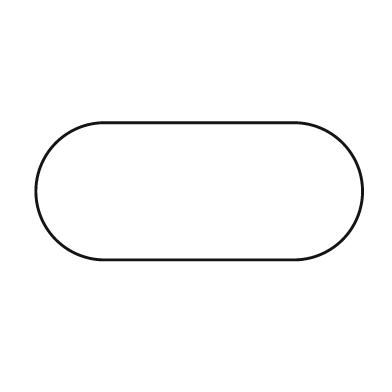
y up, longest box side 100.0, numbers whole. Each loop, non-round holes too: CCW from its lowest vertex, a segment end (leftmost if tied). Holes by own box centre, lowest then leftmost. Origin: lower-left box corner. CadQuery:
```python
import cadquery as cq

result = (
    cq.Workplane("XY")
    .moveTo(21.0, 0.0)
    .lineTo(79.0, 0.0)
    .threePointArc((100.0, 21.0), (79.0, 42.0))
    .lineTo(21.0, 42.0)
    .threePointArc((0.0, 21.0), (21.0, 0.0))
    .close()
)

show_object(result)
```